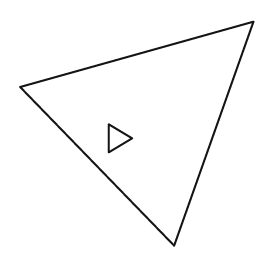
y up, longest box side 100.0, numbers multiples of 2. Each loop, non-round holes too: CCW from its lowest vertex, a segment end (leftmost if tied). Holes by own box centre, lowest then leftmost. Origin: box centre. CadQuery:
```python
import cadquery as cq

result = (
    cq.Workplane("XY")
    .moveTo(16.0, -48.0)
    .lineTo(50.0, 48.0)
    .lineTo(-50.0, 20.0)
    .close()
    .moveTo(-12.0, -8.0)
    .lineTo(-2.0, -2.0)
    .lineTo(-12.0, 4.0)
    .close()
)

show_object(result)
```